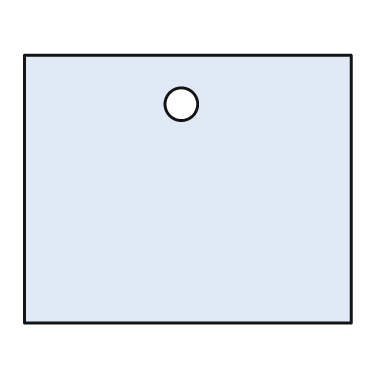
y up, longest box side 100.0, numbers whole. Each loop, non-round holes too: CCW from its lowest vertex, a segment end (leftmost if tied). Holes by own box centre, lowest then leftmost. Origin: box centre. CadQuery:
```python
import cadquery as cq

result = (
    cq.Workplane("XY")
    .moveTo(-50.0, -41.0)
    .lineTo(50.0, -41.0)
    .lineTo(50.0, 41.0)
    .lineTo(-50.0, 41.0)
    .close()
    .moveTo(-2.0, 26.0)
    .circle(5.0)
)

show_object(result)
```